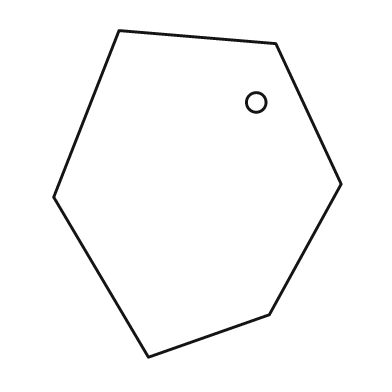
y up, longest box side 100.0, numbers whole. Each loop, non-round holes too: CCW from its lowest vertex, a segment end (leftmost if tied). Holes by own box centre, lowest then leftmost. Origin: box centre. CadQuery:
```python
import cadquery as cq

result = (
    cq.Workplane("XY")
    .moveTo(-15.0, -50.0)
    .lineTo(22.0, -37.0)
    .lineTo(44.0, 3.0)
    .lineTo(24.0, 46.0)
    .lineTo(-24.0, 50.0)
    .lineTo(-44.0, -1.0)
    .close()
    .moveTo(18.0, 28.0)
    .circle(3.0)
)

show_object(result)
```